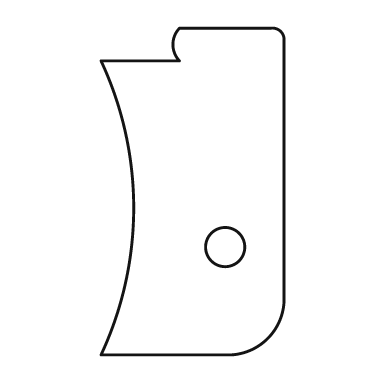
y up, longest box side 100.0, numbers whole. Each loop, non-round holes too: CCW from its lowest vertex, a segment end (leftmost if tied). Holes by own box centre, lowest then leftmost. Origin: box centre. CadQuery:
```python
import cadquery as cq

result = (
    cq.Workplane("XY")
    .moveTo(-28.0, -50.0)
    .lineTo(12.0, -50.0)
    .threePointArc((23.0, -45.0), (28.0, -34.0))
    .lineTo(28.0, 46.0)
    .threePointArc((27.0, 49.0), (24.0, 50.0))
    .lineTo(-4.0, 50.0)
    .threePointArc((-6.0, 45.0), (-4.0, 40.0))
    .lineTo(-28.0, 40.0)
    .threePointArc((-18.0, -5.0), (-28.0, -50.0))
    .close()
    .moveTo(10.0, -17.0)
    .circle(6.0)
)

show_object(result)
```